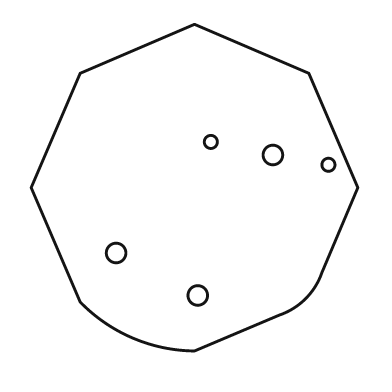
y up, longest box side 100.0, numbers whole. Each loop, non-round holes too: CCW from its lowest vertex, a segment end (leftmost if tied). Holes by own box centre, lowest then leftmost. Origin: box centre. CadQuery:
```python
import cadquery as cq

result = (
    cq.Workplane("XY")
    .moveTo(0.0, -50.0)
    .lineTo(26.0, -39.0)
    .threePointArc((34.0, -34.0), (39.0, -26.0))
    .lineTo(50.0, 0.0)
    .lineTo(35.0, 35.0)
    .lineTo(0.0, 50.0)
    .lineTo(-35.0, 35.0)
    .lineTo(-50.0, 0.0)
    .lineTo(-35.0, -35.0)
    .threePointArc((-19.0, -46.0), (0.0, -50.0))
    .close()
    .moveTo(1.0, -33.0)
    .circle(3.0)
    .moveTo(-24.0, -20.0)
    .circle(3.0)
    .moveTo(41.0, 7.0)
    .circle(2.0)
    .moveTo(24.0, 10.0)
    .circle(3.0)
    .moveTo(5.0, 14.0)
    .circle(2.0)
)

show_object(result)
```